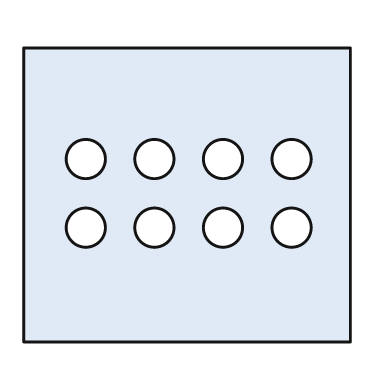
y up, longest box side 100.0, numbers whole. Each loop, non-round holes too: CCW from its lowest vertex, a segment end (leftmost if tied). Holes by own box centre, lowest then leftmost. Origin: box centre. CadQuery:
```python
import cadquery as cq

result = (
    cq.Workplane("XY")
    .moveTo(-50.0, -45.0)
    .lineTo(50.0, -45.0)
    .lineTo(50.0, 45.0)
    .lineTo(-50.0, 45.0)
    .close()
    .moveTo(-31.0, -10.0)
    .circle(6.0)
    .moveTo(-10.0, -10.0)
    .circle(6.0)
    .moveTo(11.0, -10.0)
    .circle(6.0)
    .moveTo(32.0, -10.0)
    .circle(6.0)
    .moveTo(-31.0, 11.0)
    .circle(6.0)
    .moveTo(-10.0, 11.0)
    .circle(6.0)
    .moveTo(11.0, 11.0)
    .circle(6.0)
    .moveTo(32.0, 11.0)
    .circle(6.0)
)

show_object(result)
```